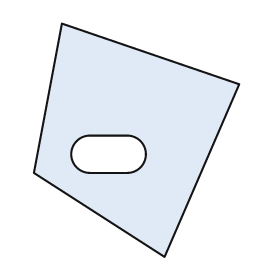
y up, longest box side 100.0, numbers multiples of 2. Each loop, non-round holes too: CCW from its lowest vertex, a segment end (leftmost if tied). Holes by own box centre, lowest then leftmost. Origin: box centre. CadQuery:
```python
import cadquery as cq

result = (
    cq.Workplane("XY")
    .moveTo(12.0, -50.0)
    .lineTo(44.0, 24.0)
    .lineTo(-32.0, 50.0)
    .lineTo(-44.0, -14.0)
    .close()
    .moveTo(-20.0, -14.0)
    .lineTo(-4.0, -14.0)
    .threePointArc((4.0, -6.0), (-4.0, 2.0))
    .lineTo(-20.0, 2.0)
    .threePointArc((-28.0, -6.0), (-20.0, -14.0))
    .close()
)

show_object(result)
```